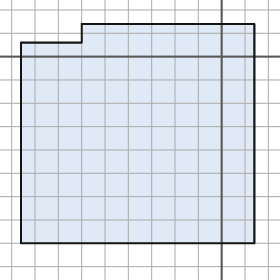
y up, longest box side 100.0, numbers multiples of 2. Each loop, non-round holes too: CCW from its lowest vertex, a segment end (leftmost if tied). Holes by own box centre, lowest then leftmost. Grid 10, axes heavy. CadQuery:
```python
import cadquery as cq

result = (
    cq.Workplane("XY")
    .moveTo(-86.0, -80.0)
    .lineTo(14.0, -80.0)
    .lineTo(14.0, 14.0)
    .lineTo(-60.0, 14.0)
    .lineTo(-60.0, 6.0)
    .lineTo(-86.0, 6.0)
    .close()
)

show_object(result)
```